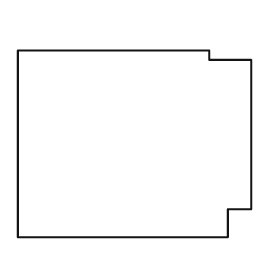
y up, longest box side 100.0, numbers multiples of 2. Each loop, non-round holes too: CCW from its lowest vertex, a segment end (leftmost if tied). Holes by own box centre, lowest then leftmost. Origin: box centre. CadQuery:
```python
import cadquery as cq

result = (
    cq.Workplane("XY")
    .moveTo(-50.0, -40.0)
    .lineTo(40.0, -40.0)
    .lineTo(40.0, -28.0)
    .lineTo(50.0, -28.0)
    .lineTo(50.0, 36.0)
    .lineTo(32.0, 36.0)
    .lineTo(32.0, 40.0)
    .lineTo(-50.0, 40.0)
    .close()
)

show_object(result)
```